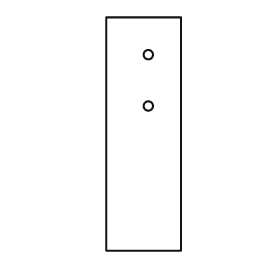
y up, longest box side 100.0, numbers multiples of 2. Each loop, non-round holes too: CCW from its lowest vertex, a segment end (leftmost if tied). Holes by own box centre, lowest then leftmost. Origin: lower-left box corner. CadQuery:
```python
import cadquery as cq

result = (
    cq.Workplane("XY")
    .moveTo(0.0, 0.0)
    .lineTo(32.0, 0.0)
    .lineTo(32.0, 100.0)
    .lineTo(0.0, 100.0)
    .close()
    .moveTo(18.0, 62.0)
    .circle(2.0)
    .moveTo(18.0, 84.0)
    .circle(2.0)
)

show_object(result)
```